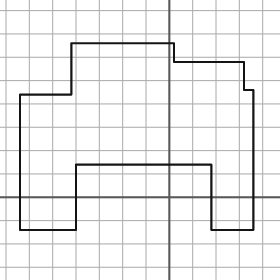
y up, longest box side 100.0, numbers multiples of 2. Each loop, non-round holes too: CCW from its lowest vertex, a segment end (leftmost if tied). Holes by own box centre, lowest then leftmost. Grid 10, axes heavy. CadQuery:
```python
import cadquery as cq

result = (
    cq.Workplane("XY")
    .moveTo(-64.0, -14.0)
    .lineTo(-40.0, -14.0)
    .lineTo(-40.0, 14.0)
    .lineTo(18.0, 14.0)
    .lineTo(18.0, -14.0)
    .lineTo(36.0, -14.0)
    .lineTo(36.0, 46.0)
    .lineTo(32.0, 46.0)
    .lineTo(32.0, 58.0)
    .lineTo(2.0, 58.0)
    .lineTo(2.0, 66.0)
    .lineTo(-42.0, 66.0)
    .lineTo(-42.0, 44.0)
    .lineTo(-64.0, 44.0)
    .close()
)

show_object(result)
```